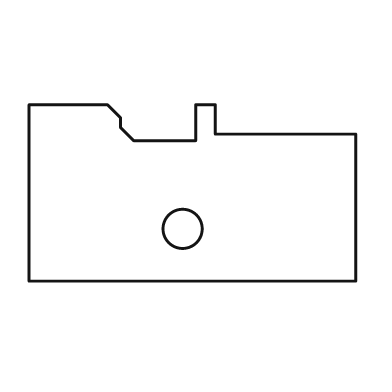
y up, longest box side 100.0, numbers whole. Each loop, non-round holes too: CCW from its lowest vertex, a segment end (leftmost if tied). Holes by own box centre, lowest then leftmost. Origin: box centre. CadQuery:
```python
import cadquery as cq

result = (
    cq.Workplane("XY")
    .moveTo(-50.0, -27.0)
    .lineTo(50.0, -27.0)
    .lineTo(50.0, 18.0)
    .lineTo(7.0, 18.0)
    .lineTo(7.0, 27.0)
    .lineTo(1.0, 27.0)
    .lineTo(1.0, 16.0)
    .lineTo(-18.0, 16.0)
    .lineTo(-22.0, 20.0)
    .lineTo(-22.0, 23.0)
    .lineTo(-26.0, 27.0)
    .lineTo(-50.0, 27.0)
    .close()
    .moveTo(-3.0, -11.0)
    .circle(6.0)
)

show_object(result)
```